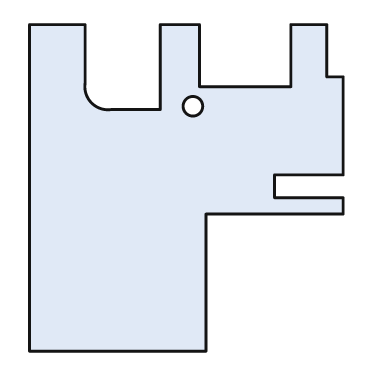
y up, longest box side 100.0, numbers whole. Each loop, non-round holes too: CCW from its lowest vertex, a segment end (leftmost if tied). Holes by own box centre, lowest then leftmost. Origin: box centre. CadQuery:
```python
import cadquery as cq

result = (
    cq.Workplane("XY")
    .moveTo(-48.0, -50.0)
    .lineTo(6.0, -50.0)
    .lineTo(6.0, -8.0)
    .lineTo(48.0, -8.0)
    .lineTo(48.0, -3.0)
    .lineTo(27.0, -3.0)
    .lineTo(27.0, 4.0)
    .lineTo(48.0, 4.0)
    .lineTo(48.0, 34.0)
    .lineTo(43.0, 34.0)
    .lineTo(43.0, 50.0)
    .lineTo(32.0, 50.0)
    .lineTo(32.0, 31.0)
    .lineTo(4.0, 31.0)
    .lineTo(4.0, 50.0)
    .lineTo(-8.0, 50.0)
    .lineTo(-8.0, 24.0)
    .lineTo(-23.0, 24.0)
    .threePointArc((-29.0, 26.0), (-31.0, 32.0))
    .lineTo(-31.0, 50.0)
    .lineTo(-48.0, 50.0)
    .close()
    .moveTo(2.0, 25.0)
    .circle(3.0)
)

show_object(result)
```